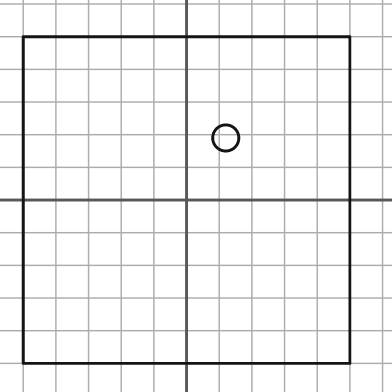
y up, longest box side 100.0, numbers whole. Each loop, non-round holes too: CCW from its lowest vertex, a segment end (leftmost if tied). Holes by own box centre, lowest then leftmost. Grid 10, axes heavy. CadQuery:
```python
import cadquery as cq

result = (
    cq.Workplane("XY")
    .moveTo(-50.0, -50.0)
    .lineTo(50.0, -50.0)
    .lineTo(50.0, 50.0)
    .lineTo(-50.0, 50.0)
    .close()
    .moveTo(12.0, 19.0)
    .circle(4.0)
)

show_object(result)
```